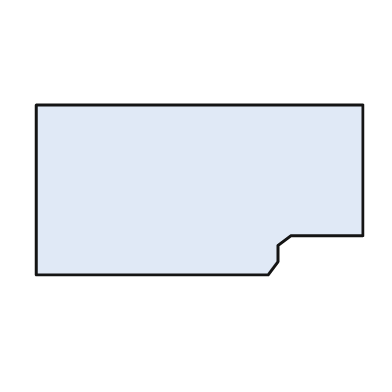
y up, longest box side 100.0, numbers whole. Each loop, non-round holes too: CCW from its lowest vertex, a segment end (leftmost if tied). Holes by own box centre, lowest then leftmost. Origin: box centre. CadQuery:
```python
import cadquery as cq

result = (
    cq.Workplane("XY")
    .moveTo(-50.0, -26.0)
    .lineTo(21.0, -26.0)
    .lineTo(24.0, -22.0)
    .lineTo(24.0, -17.0)
    .lineTo(28.0, -14.0)
    .lineTo(50.0, -14.0)
    .lineTo(50.0, 26.0)
    .lineTo(-50.0, 26.0)
    .close()
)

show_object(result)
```